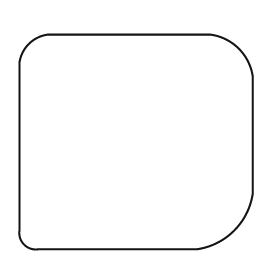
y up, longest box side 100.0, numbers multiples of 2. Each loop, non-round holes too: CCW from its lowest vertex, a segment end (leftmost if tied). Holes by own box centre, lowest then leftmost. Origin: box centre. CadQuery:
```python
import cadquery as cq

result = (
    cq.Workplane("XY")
    .moveTo(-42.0, -46.0)
    .lineTo(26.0, -46.0)
    .threePointArc((42.0, -38.0), (50.0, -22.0))
    .lineTo(50.0, 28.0)
    .threePointArc((44.0, 40.0), (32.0, 46.0))
    .lineTo(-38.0, 46.0)
    .threePointArc((-46.0, 42.0), (-50.0, 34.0))
    .lineTo(-50.0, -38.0)
    .threePointArc((-48.0, -44.0), (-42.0, -46.0))
    .close()
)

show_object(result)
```